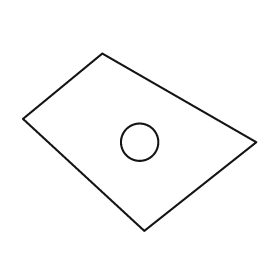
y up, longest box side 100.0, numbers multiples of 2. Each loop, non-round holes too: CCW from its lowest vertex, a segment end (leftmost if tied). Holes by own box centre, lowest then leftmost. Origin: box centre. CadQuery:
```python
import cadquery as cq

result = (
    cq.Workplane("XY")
    .moveTo(2.0, -38.0)
    .lineTo(50.0, 0.0)
    .lineTo(-16.0, 38.0)
    .lineTo(-50.0, 10.0)
    .close()
    .moveTo(0.0, 0.0)
    .circle(8.0)
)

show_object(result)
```